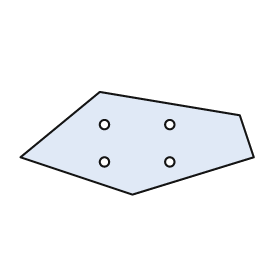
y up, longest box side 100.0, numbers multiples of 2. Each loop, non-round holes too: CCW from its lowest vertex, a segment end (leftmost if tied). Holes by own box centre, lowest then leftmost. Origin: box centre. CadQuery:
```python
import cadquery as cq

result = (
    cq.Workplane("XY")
    .moveTo(-2.0, -22.0)
    .lineTo(50.0, -6.0)
    .lineTo(44.0, 12.0)
    .lineTo(-16.0, 22.0)
    .lineTo(-50.0, -6.0)
    .close()
    .moveTo(-14.0, -8.0)
    .circle(2.0)
    .moveTo(14.0, -8.0)
    .circle(2.0)
    .moveTo(-14.0, 8.0)
    .circle(2.0)
    .moveTo(14.0, 8.0)
    .circle(2.0)
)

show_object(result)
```